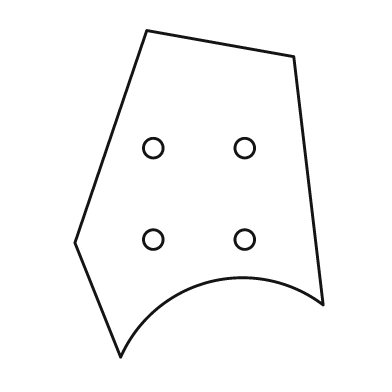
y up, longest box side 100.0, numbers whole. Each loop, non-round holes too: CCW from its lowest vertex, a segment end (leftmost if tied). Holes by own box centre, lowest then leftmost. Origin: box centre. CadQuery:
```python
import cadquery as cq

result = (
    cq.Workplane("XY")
    .moveTo(-24.0, -50.0)
    .threePointArc((3.0, -27.0), (38.0, -34.0))
    .lineTo(29.0, 42.0)
    .lineTo(-16.0, 50.0)
    .lineTo(-38.0, -15.0)
    .close()
    .moveTo(-14.0, -14.0)
    .circle(3.0)
    .moveTo(14.0, -14.0)
    .circle(3.0)
    .moveTo(-14.0, 14.0)
    .circle(3.0)
    .moveTo(14.0, 14.0)
    .circle(3.0)
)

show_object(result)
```